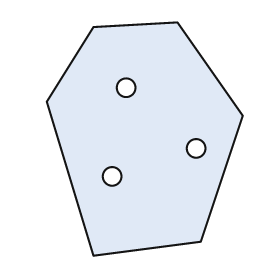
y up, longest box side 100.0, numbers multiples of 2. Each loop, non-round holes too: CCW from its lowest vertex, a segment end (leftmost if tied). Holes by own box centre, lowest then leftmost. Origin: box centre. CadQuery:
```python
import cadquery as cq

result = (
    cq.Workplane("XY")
    .moveTo(-22.0, -50.0)
    .lineTo(24.0, -44.0)
    .lineTo(42.0, 10.0)
    .lineTo(14.0, 50.0)
    .lineTo(-22.0, 48.0)
    .lineTo(-42.0, 16.0)
    .close()
    .moveTo(-14.0, -16.0)
    .circle(4.0)
    .moveTo(22.0, -4.0)
    .circle(4.0)
    .moveTo(-8.0, 22.0)
    .circle(4.0)
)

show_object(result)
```